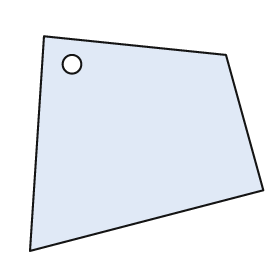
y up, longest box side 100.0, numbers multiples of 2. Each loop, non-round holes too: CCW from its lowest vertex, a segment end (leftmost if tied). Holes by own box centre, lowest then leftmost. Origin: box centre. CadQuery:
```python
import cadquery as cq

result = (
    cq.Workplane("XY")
    .moveTo(-50.0, -46.0)
    .lineTo(50.0, -20.0)
    .lineTo(34.0, 38.0)
    .lineTo(-44.0, 46.0)
    .close()
    .moveTo(-32.0, 34.0)
    .circle(4.0)
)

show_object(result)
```